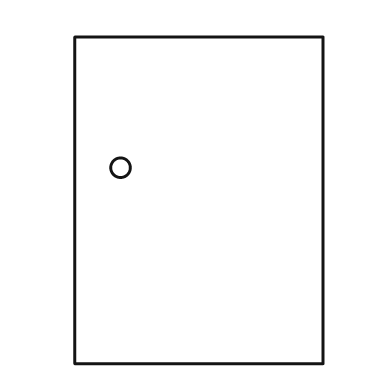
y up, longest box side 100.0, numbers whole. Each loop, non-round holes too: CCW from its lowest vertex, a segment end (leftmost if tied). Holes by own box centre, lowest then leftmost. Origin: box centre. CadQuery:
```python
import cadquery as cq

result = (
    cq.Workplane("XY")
    .moveTo(-38.0, -50.0)
    .lineTo(38.0, -50.0)
    .lineTo(38.0, 50.0)
    .lineTo(-38.0, 50.0)
    .close()
    .moveTo(-24.0, 10.0)
    .circle(3.0)
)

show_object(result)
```